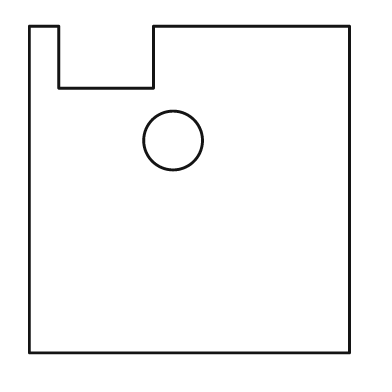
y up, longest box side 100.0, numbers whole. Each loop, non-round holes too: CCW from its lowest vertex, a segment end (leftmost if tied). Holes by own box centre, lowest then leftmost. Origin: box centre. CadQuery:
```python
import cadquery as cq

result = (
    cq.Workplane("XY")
    .moveTo(-49.0, -50.0)
    .lineTo(49.0, -50.0)
    .lineTo(49.0, 50.0)
    .lineTo(-11.0, 50.0)
    .lineTo(-11.0, 31.0)
    .lineTo(-40.0, 31.0)
    .lineTo(-40.0, 50.0)
    .lineTo(-49.0, 50.0)
    .close()
    .moveTo(-5.0, 15.0)
    .circle(9.0)
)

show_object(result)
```